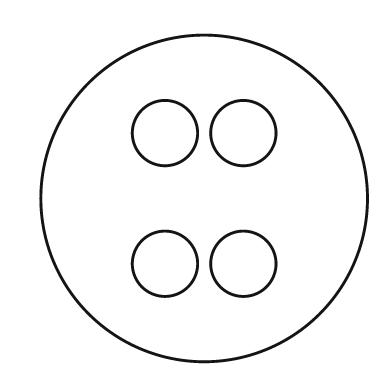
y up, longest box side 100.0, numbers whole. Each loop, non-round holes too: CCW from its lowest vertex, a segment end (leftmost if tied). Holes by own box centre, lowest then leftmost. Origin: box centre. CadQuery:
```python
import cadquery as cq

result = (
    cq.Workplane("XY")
    .moveTo(0.0, 0.0)
    .circle(50.0)
    .moveTo(-12.0, -20.0)
    .circle(10.0)
    .moveTo(12.0, -20.0)
    .circle(10.0)
    .moveTo(-12.0, 20.0)
    .circle(10.0)
    .moveTo(12.0, 20.0)
    .circle(10.0)
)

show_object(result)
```